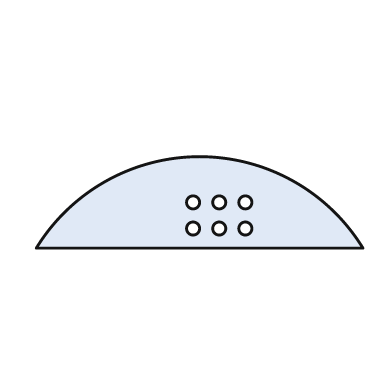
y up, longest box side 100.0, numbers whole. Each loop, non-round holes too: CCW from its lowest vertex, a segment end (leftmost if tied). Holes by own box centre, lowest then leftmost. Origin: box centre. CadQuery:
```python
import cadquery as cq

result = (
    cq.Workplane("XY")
    .moveTo(-50.0, -14.0)
    .lineTo(50.0, -14.0)
    .threePointArc((0.0, 14.0), (-50.0, -14.0))
    .close()
    .moveTo(-2.0, -8.0)
    .circle(2.0)
    .moveTo(6.0, -8.0)
    .circle(2.0)
    .moveTo(14.0, -8.0)
    .circle(2.0)
    .moveTo(-2.0, 0.0)
    .circle(2.0)
    .moveTo(6.0, 0.0)
    .circle(2.0)
    .moveTo(14.0, 0.0)
    .circle(2.0)
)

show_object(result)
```